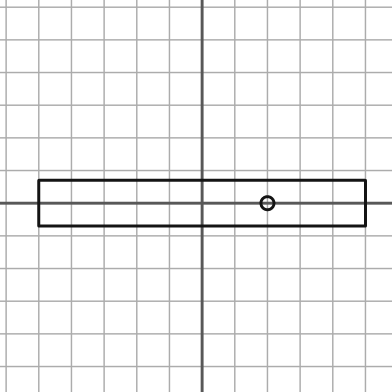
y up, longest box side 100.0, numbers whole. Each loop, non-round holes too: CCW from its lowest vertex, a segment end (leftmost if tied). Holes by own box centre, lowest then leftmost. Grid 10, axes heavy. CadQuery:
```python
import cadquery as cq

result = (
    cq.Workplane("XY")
    .moveTo(-50.0, -7.0)
    .lineTo(50.0, -7.0)
    .lineTo(50.0, 7.0)
    .lineTo(-50.0, 7.0)
    .close()
    .moveTo(20.0, 0.0)
    .circle(2.0)
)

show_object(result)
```